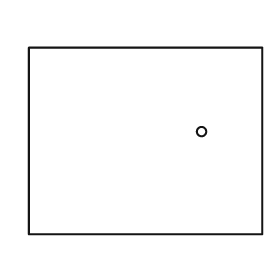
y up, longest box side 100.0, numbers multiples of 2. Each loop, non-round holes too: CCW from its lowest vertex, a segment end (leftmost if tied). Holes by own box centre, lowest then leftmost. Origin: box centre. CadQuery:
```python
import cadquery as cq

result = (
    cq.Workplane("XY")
    .moveTo(-50.0, -40.0)
    .lineTo(50.0, -40.0)
    .lineTo(50.0, 40.0)
    .lineTo(-50.0, 40.0)
    .close()
    .moveTo(24.0, 4.0)
    .circle(2.0)
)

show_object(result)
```